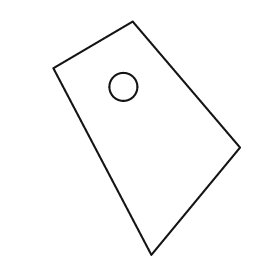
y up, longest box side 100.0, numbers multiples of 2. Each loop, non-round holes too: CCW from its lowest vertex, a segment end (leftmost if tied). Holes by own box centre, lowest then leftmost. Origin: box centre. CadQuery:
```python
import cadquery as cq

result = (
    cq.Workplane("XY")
    .moveTo(2.0, -50.0)
    .lineTo(40.0, -4.0)
    .lineTo(-6.0, 50.0)
    .lineTo(-40.0, 30.0)
    .close()
    .moveTo(-10.0, 22.0)
    .circle(6.0)
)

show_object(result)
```